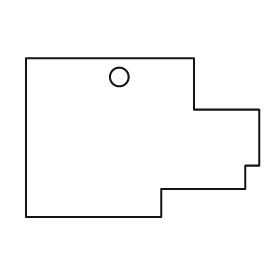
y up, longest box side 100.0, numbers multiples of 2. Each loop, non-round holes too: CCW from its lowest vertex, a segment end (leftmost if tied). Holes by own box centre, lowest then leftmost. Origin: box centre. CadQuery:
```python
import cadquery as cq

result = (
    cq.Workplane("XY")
    .moveTo(-50.0, -34.0)
    .lineTo(8.0, -34.0)
    .lineTo(8.0, -22.0)
    .lineTo(44.0, -22.0)
    .lineTo(44.0, -12.0)
    .lineTo(50.0, -12.0)
    .lineTo(50.0, 12.0)
    .lineTo(22.0, 12.0)
    .lineTo(22.0, 34.0)
    .lineTo(-50.0, 34.0)
    .close()
    .moveTo(-10.0, 26.0)
    .circle(4.0)
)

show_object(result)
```